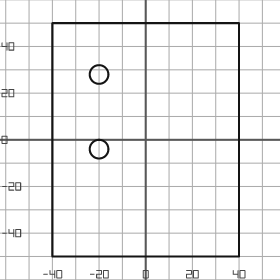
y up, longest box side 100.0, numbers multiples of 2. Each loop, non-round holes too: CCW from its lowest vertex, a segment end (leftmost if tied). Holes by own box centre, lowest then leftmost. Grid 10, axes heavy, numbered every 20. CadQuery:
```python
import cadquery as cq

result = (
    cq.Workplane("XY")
    .moveTo(-40.0, -50.0)
    .lineTo(40.0, -50.0)
    .lineTo(40.0, 50.0)
    .lineTo(-40.0, 50.0)
    .close()
    .moveTo(-20.0, -4.0)
    .circle(4.0)
    .moveTo(-20.0, 28.0)
    .circle(4.0)
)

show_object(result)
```